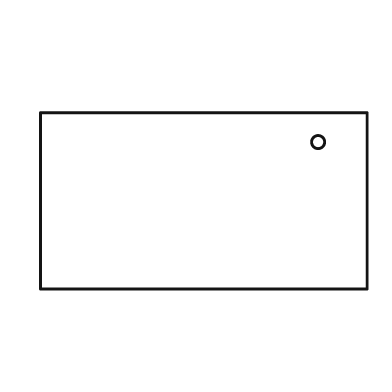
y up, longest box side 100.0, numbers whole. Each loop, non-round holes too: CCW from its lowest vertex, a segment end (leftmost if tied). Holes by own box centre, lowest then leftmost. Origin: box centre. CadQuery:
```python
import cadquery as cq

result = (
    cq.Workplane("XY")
    .moveTo(-50.0, -27.0)
    .lineTo(50.0, -27.0)
    .lineTo(50.0, 27.0)
    .lineTo(-50.0, 27.0)
    .close()
    .moveTo(35.0, 18.0)
    .circle(2.0)
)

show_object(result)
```